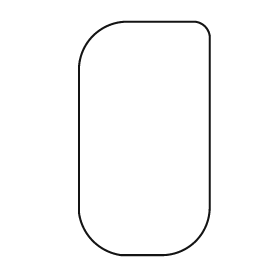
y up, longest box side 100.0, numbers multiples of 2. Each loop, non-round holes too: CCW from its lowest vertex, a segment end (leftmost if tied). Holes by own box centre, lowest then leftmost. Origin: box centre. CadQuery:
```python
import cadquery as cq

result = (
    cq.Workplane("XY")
    .moveTo(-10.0, -50.0)
    .lineTo(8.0, -50.0)
    .threePointArc((22.0, -44.0), (28.0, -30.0))
    .lineTo(28.0, 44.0)
    .threePointArc((26.0, 48.0), (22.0, 50.0))
    .lineTo(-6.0, 50.0)
    .threePointArc((-22.0, 44.0), (-28.0, 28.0))
    .lineTo(-28.0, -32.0)
    .threePointArc((-22.0, -44.0), (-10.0, -50.0))
    .close()
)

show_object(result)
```